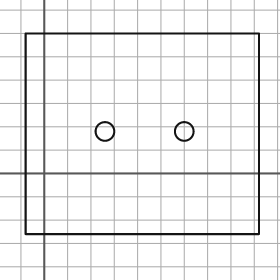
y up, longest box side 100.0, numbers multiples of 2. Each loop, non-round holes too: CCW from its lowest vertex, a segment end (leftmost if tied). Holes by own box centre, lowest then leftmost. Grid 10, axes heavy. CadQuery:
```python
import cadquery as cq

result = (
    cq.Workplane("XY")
    .moveTo(-8.0, -26.0)
    .lineTo(92.0, -26.0)
    .lineTo(92.0, 60.0)
    .lineTo(-8.0, 60.0)
    .close()
    .moveTo(26.0, 18.0)
    .circle(4.0)
    .moveTo(60.0, 18.0)
    .circle(4.0)
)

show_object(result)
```